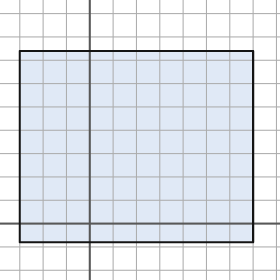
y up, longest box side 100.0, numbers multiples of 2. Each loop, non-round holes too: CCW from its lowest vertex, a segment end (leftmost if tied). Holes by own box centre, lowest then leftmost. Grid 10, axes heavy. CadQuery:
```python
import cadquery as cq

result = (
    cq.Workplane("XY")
    .moveTo(-30.0, -8.0)
    .lineTo(70.0, -8.0)
    .lineTo(70.0, 74.0)
    .lineTo(-30.0, 74.0)
    .close()
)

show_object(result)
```